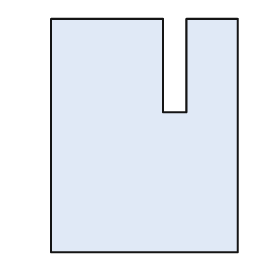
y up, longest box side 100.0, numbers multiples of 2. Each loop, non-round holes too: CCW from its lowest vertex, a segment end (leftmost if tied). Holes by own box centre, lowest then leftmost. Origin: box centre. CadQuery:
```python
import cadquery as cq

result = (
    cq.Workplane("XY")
    .moveTo(-40.0, -50.0)
    .lineTo(40.0, -50.0)
    .lineTo(40.0, 50.0)
    .lineTo(18.0, 50.0)
    .lineTo(18.0, 10.0)
    .lineTo(8.0, 10.0)
    .lineTo(8.0, 50.0)
    .lineTo(-40.0, 50.0)
    .close()
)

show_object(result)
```